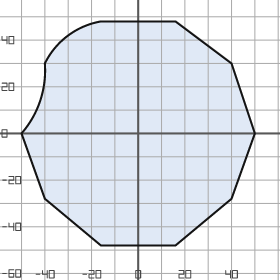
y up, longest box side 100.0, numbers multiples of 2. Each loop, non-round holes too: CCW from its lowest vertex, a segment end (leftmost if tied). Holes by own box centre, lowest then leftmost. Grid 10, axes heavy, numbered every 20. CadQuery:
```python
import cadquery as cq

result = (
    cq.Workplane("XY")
    .moveTo(-16.0, -48.0)
    .lineTo(16.0, -48.0)
    .lineTo(40.0, -28.0)
    .lineTo(50.0, 0.0)
    .lineTo(40.0, 30.0)
    .lineTo(16.0, 48.0)
    .lineTo(-16.0, 48.0)
    .threePointArc((-30.0, 42.0), (-40.0, 30.0))
    .threePointArc((-42.0, 14.0), (-50.0, 0.0))
    .lineTo(-40.0, -28.0)
    .close()
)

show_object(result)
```